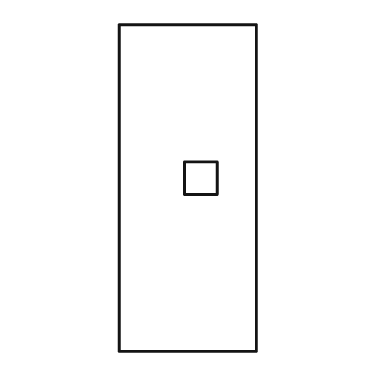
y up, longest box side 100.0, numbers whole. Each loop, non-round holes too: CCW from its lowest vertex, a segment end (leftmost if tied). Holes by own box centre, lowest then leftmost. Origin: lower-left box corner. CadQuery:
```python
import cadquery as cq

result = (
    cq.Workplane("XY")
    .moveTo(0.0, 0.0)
    .lineTo(42.0, 0.0)
    .lineTo(42.0, 100.0)
    .lineTo(0.0, 100.0)
    .close()
    .moveTo(20.0, 48.0)
    .lineTo(30.0, 48.0)
    .lineTo(30.0, 58.0)
    .lineTo(20.0, 58.0)
    .close()
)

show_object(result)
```